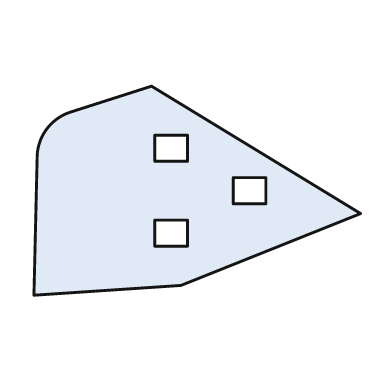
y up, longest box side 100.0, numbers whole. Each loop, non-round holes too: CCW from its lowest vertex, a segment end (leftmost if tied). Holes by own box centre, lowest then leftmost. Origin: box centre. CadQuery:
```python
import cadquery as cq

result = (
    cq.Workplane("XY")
    .moveTo(-50.0, -32.0)
    .lineTo(-5.0, -29.0)
    .lineTo(50.0, -7.0)
    .lineTo(-14.0, 32.0)
    .lineTo(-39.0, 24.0)
    .threePointArc((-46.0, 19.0), (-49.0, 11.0))
    .close()
    .moveTo(-13.0, -17.0)
    .lineTo(-3.0, -17.0)
    .lineTo(-3.0, -9.0)
    .lineTo(-13.0, -9.0)
    .close()
    .moveTo(11.0, -4.0)
    .lineTo(21.0, -4.0)
    .lineTo(21.0, 4.0)
    .lineTo(11.0, 4.0)
    .close()
    .moveTo(-13.0, 9.0)
    .lineTo(-3.0, 9.0)
    .lineTo(-3.0, 17.0)
    .lineTo(-13.0, 17.0)
    .close()
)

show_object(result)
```